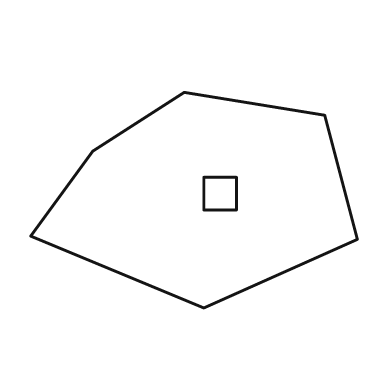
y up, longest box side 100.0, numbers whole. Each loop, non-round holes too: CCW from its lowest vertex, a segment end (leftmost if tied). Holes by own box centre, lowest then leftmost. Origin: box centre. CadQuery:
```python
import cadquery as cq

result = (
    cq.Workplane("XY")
    .moveTo(3.0, -33.0)
    .lineTo(50.0, -12.0)
    .lineTo(40.0, 26.0)
    .lineTo(-3.0, 33.0)
    .lineTo(-31.0, 15.0)
    .lineTo(-50.0, -11.0)
    .close()
    .moveTo(3.0, -3.0)
    .lineTo(13.0, -3.0)
    .lineTo(13.0, 7.0)
    .lineTo(3.0, 7.0)
    .close()
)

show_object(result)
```